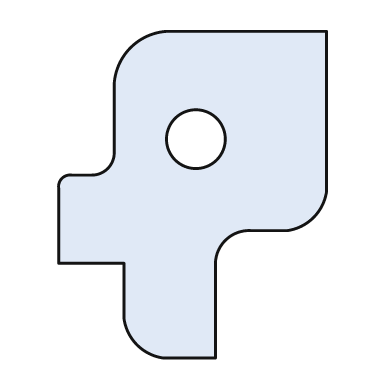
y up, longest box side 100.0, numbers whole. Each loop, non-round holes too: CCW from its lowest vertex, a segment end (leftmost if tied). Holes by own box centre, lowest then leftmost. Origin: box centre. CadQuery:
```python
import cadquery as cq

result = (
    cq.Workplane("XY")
    .moveTo(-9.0, -50.0)
    .lineTo(7.0, -50.0)
    .lineTo(7.0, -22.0)
    .threePointArc((10.0, -14.0), (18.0, -11.0))
    .lineTo(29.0, -11.0)
    .threePointArc((37.0, -7.0), (41.0, 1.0))
    .lineTo(41.0, 50.0)
    .lineTo(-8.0, 50.0)
    .threePointArc((-19.0, 45.0), (-24.0, 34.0))
    .lineTo(-24.0, 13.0)
    .threePointArc((-26.0, 8.0), (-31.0, 6.0))
    .lineTo(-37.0, 6.0)
    .threePointArc((-40.0, 5.0), (-41.0, 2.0))
    .lineTo(-41.0, -21.0)
    .lineTo(-21.0, -21.0)
    .lineTo(-21.0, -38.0)
    .threePointArc((-17.0, -46.0), (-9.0, -50.0))
    .close()
    .moveTo(1.0, 17.0)
    .circle(9.0)
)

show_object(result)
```